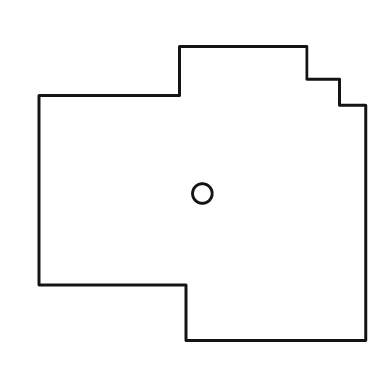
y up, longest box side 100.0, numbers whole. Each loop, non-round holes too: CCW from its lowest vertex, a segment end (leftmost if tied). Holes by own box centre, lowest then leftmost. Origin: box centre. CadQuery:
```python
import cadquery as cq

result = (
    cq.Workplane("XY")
    .moveTo(-5.0, -45.0)
    .lineTo(50.0, -45.0)
    .lineTo(50.0, 27.0)
    .lineTo(42.0, 27.0)
    .lineTo(42.0, 35.0)
    .lineTo(32.0, 35.0)
    .lineTo(32.0, 45.0)
    .lineTo(-7.0, 45.0)
    .lineTo(-7.0, 30.0)
    .lineTo(-50.0, 30.0)
    .lineTo(-50.0, -28.0)
    .lineTo(-5.0, -28.0)
    .close()
    .moveTo(0.0, 0.0)
    .circle(3.0)
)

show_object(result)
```